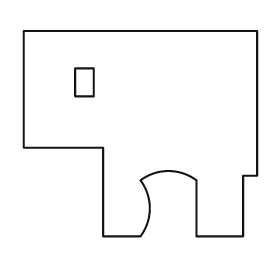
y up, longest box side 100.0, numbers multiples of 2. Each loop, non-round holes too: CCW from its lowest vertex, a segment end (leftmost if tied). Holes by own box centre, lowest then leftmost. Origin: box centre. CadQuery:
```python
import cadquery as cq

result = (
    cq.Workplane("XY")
    .moveTo(-16.0, -44.0)
    .lineTo(0.0, -44.0)
    .threePointArc((4.0, -32.0), (0.0, -20.0))
    .threePointArc((12.0, -16.0), (24.0, -20.0))
    .lineTo(24.0, -44.0)
    .lineTo(44.0, -44.0)
    .lineTo(44.0, -18.0)
    .lineTo(50.0, -18.0)
    .lineTo(50.0, 44.0)
    .lineTo(-50.0, 44.0)
    .lineTo(-50.0, -6.0)
    .lineTo(-16.0, -6.0)
    .close()
    .moveTo(-28.0, 16.0)
    .lineTo(-20.0, 16.0)
    .lineTo(-20.0, 28.0)
    .lineTo(-28.0, 28.0)
    .close()
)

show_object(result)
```